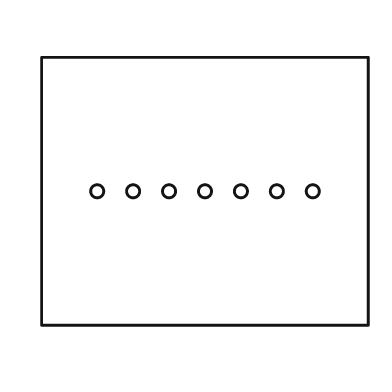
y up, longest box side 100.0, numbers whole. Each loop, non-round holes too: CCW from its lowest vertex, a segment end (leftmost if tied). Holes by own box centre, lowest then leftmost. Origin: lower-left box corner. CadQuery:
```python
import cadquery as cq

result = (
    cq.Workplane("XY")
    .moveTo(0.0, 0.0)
    .lineTo(100.0, 0.0)
    .lineTo(100.0, 82.0)
    .lineTo(0.0, 82.0)
    .close()
    .moveTo(17.0, 41.0)
    .circle(2.0)
    .moveTo(28.0, 41.0)
    .circle(2.0)
    .moveTo(39.0, 41.0)
    .circle(2.0)
    .moveTo(50.0, 41.0)
    .circle(2.0)
    .moveTo(61.0, 41.0)
    .circle(2.0)
    .moveTo(72.0, 41.0)
    .circle(2.0)
    .moveTo(83.0, 41.0)
    .circle(2.0)
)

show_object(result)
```